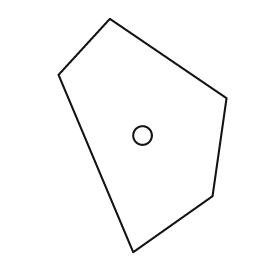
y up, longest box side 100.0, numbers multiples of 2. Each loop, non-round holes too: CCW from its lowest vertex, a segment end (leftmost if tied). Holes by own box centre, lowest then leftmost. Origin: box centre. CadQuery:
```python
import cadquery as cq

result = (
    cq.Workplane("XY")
    .moveTo(-4.0, -50.0)
    .lineTo(30.0, -26.0)
    .lineTo(36.0, 16.0)
    .lineTo(-14.0, 50.0)
    .lineTo(-36.0, 26.0)
    .close()
    .moveTo(0.0, 0.0)
    .circle(4.0)
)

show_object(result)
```